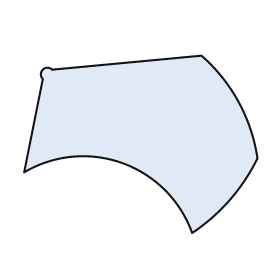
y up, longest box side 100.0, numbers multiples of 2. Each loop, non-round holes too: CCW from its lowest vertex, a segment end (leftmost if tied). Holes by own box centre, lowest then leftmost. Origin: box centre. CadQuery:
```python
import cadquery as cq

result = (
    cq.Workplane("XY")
    .moveTo(22.0, -38.0)
    .threePointArc((38.0, -24.0), (50.0, -6.0))
    .threePointArc((42.0, 18.0), (26.0, 38.0))
    .lineTo(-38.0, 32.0)
    .threePointArc((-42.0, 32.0), (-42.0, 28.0))
    .lineTo(-50.0, -12.0)
    .threePointArc((-8.0, -8.0), (22.0, -38.0))
    .close()
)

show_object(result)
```